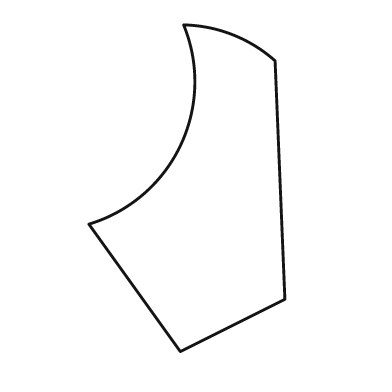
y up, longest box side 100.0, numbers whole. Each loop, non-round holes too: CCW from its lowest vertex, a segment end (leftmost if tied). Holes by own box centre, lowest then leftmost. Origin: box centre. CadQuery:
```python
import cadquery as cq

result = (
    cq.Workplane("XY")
    .moveTo(-2.0, -50.0)
    .lineTo(30.0, -34.0)
    .lineTo(27.0, 39.0)
    .threePointArc((14.0, 47.0), (-1.0, 50.0))
    .threePointArc((-2.0, 13.0), (-30.0, -11.0))
    .close()
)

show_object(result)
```